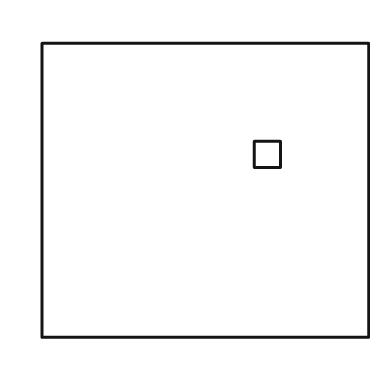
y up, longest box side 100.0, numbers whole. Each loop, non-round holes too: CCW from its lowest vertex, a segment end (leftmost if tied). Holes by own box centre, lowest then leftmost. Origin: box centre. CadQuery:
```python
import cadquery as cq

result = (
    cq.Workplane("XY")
    .moveTo(-50.0, -45.0)
    .lineTo(50.0, -45.0)
    .lineTo(50.0, 45.0)
    .lineTo(-50.0, 45.0)
    .close()
    .moveTo(15.0, 7.0)
    .lineTo(23.0, 7.0)
    .lineTo(23.0, 15.0)
    .lineTo(15.0, 15.0)
    .close()
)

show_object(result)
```